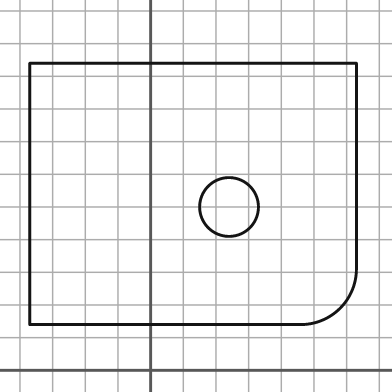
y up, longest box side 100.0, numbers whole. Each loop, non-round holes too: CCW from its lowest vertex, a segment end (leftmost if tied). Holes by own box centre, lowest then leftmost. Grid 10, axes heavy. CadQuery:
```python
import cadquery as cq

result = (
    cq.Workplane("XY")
    .moveTo(-37.0, 14.0)
    .lineTo(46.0, 14.0)
    .threePointArc((58.0, 19.0), (63.0, 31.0))
    .lineTo(63.0, 94.0)
    .lineTo(-37.0, 94.0)
    .close()
    .moveTo(24.0, 50.0)
    .circle(9.0)
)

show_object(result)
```